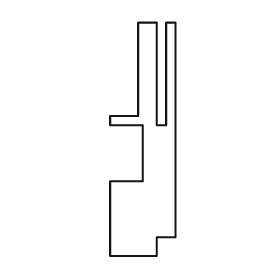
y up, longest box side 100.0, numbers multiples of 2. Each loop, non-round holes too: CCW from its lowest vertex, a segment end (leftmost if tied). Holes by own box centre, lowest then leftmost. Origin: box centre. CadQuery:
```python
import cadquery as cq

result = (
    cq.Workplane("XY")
    .moveTo(-14.0, -50.0)
    .lineTo(6.0, -50.0)
    .lineTo(6.0, -42.0)
    .lineTo(14.0, -42.0)
    .lineTo(14.0, 50.0)
    .lineTo(10.0, 50.0)
    .lineTo(10.0, 6.0)
    .lineTo(6.0, 6.0)
    .lineTo(6.0, 50.0)
    .lineTo(-2.0, 50.0)
    .lineTo(-2.0, 10.0)
    .lineTo(-14.0, 10.0)
    .lineTo(-14.0, 6.0)
    .lineTo(0.0, 6.0)
    .lineTo(0.0, -18.0)
    .lineTo(-14.0, -18.0)
    .close()
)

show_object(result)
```